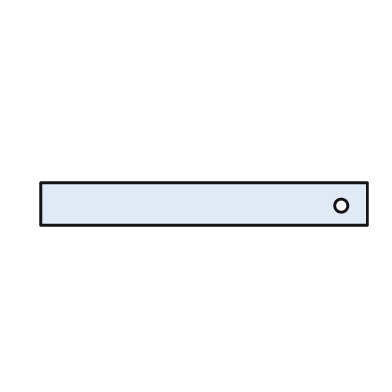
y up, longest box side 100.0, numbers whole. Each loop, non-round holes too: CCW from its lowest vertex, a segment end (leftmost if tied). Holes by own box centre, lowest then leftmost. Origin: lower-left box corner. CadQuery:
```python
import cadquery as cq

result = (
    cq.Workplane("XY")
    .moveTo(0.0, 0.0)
    .lineTo(100.0, 0.0)
    .lineTo(100.0, 13.0)
    .lineTo(0.0, 13.0)
    .close()
    .moveTo(92.0, 6.0)
    .circle(2.0)
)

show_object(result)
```